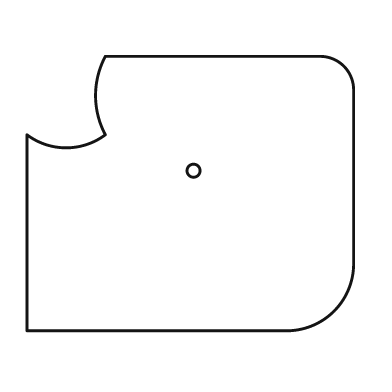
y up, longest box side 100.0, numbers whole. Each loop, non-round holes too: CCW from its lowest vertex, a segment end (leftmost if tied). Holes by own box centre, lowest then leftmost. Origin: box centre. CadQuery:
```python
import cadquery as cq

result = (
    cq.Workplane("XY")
    .moveTo(-50.0, -42.0)
    .lineTo(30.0, -42.0)
    .threePointArc((44.0, -36.0), (50.0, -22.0))
    .lineTo(50.0, 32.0)
    .threePointArc((47.0, 39.0), (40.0, 42.0))
    .lineTo(-26.0, 42.0)
    .threePointArc((-29.0, 30.0), (-26.0, 18.0))
    .threePointArc((-38.0, 14.0), (-50.0, 18.0))
    .close()
    .moveTo(1.0, 7.0)
    .circle(2.0)
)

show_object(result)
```